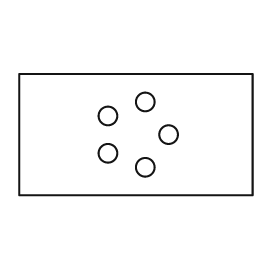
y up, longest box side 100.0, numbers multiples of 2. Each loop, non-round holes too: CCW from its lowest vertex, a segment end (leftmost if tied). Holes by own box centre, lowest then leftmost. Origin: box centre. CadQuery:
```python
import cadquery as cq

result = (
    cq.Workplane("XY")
    .moveTo(-50.0, -26.0)
    .lineTo(50.0, -26.0)
    .lineTo(50.0, 26.0)
    .lineTo(-50.0, 26.0)
    .close()
    .moveTo(4.0, -14.0)
    .circle(4.0)
    .moveTo(-12.0, -8.0)
    .circle(4.0)
    .moveTo(14.0, 0.0)
    .circle(4.0)
    .moveTo(-12.0, 8.0)
    .circle(4.0)
    .moveTo(4.0, 14.0)
    .circle(4.0)
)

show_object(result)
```